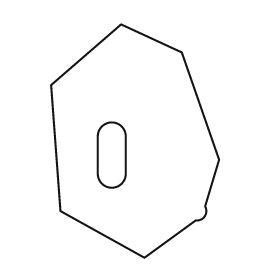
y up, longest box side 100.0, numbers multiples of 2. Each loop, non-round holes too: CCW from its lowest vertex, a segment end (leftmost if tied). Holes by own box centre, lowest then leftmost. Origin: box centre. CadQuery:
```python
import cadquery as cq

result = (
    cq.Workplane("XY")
    .moveTo(4.0, -50.0)
    .lineTo(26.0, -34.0)
    .threePointArc((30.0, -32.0), (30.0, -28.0))
    .lineTo(36.0, -8.0)
    .lineTo(20.0, 38.0)
    .lineTo(-6.0, 50.0)
    .lineTo(-36.0, 24.0)
    .lineTo(-32.0, -30.0)
    .close()
    .moveTo(-16.0, -14.0)
    .threePointArc((-10.0, -20.0), (-4.0, -14.0))
    .lineTo(-4.0, 2.0)
    .threePointArc((-10.0, 8.0), (-16.0, 2.0))
    .close()
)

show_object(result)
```